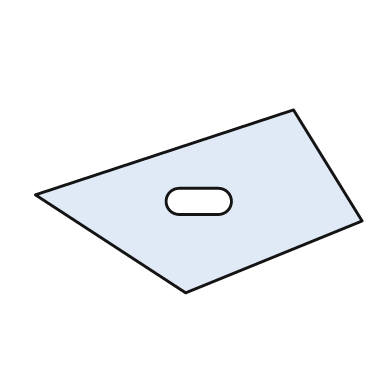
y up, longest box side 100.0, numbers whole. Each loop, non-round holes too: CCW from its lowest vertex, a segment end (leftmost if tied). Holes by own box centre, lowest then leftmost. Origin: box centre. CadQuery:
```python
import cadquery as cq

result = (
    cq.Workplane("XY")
    .moveTo(-4.0, -28.0)
    .lineTo(50.0, -6.0)
    .lineTo(29.0, 28.0)
    .lineTo(-50.0, 2.0)
    .close()
    .moveTo(-6.0, -4.0)
    .lineTo(6.0, -4.0)
    .threePointArc((10.0, 0.0), (6.0, 4.0))
    .lineTo(-6.0, 4.0)
    .threePointArc((-10.0, 0.0), (-6.0, -4.0))
    .close()
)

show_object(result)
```